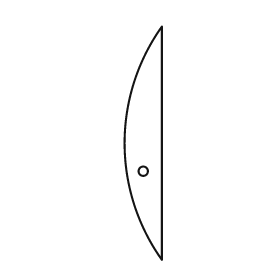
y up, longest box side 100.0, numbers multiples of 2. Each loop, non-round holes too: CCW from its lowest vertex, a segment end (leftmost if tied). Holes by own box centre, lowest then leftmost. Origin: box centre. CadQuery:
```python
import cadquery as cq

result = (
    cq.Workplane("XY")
    .moveTo(8.0, -50.0)
    .lineTo(8.0, 50.0)
    .threePointArc((-8.0, 0.0), (8.0, -50.0))
    .close()
    .moveTo(0.0, -12.0)
    .circle(2.0)
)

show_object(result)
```